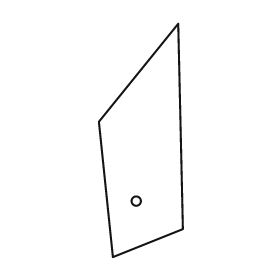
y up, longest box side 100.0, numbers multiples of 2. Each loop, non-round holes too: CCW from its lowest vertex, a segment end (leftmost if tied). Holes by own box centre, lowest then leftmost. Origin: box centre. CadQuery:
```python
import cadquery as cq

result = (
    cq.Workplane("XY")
    .moveTo(-12.0, -50.0)
    .lineTo(18.0, -38.0)
    .lineTo(16.0, 50.0)
    .lineTo(-18.0, 8.0)
    .close()
    .moveTo(-2.0, -26.0)
    .circle(2.0)
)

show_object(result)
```